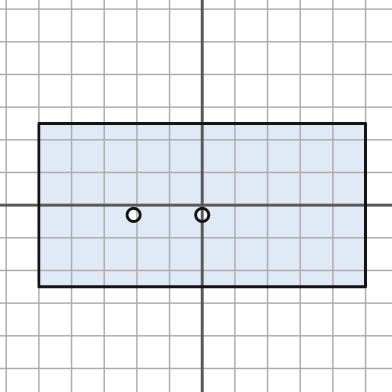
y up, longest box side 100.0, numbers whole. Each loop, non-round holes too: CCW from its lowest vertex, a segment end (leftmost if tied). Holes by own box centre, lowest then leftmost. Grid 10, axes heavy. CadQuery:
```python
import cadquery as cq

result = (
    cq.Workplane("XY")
    .moveTo(-50.0, -25.0)
    .lineTo(50.0, -25.0)
    .lineTo(50.0, 25.0)
    .lineTo(-50.0, 25.0)
    .close()
    .moveTo(-21.0, -3.0)
    .circle(2.0)
    .moveTo(0.0, -3.0)
    .circle(2.0)
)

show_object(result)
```